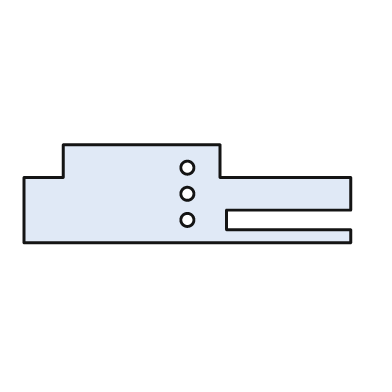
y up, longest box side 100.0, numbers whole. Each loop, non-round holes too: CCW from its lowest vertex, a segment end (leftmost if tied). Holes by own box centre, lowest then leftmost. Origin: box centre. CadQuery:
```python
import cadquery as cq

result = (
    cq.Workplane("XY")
    .moveTo(-50.0, -15.0)
    .lineTo(50.0, -15.0)
    .lineTo(50.0, -11.0)
    .lineTo(12.0, -11.0)
    .lineTo(12.0, -5.0)
    .lineTo(50.0, -5.0)
    .lineTo(50.0, 5.0)
    .lineTo(10.0, 5.0)
    .lineTo(10.0, 15.0)
    .lineTo(-38.0, 15.0)
    .lineTo(-38.0, 5.0)
    .lineTo(-50.0, 5.0)
    .close()
    .moveTo(0.0, -8.0)
    .circle(2.0)
    .moveTo(0.0, 0.0)
    .circle(2.0)
    .moveTo(0.0, 8.0)
    .circle(2.0)
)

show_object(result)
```